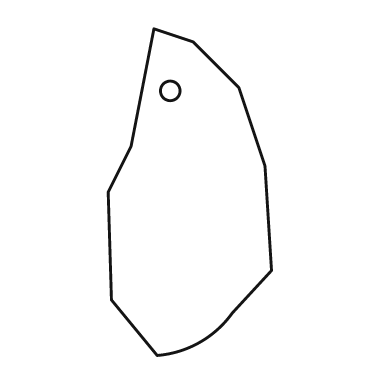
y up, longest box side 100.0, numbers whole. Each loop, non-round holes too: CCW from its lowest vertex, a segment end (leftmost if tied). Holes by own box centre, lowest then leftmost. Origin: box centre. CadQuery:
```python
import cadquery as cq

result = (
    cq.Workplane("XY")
    .moveTo(-10.0, -50.0)
    .threePointArc((3.0, -46.0), (13.0, -37.0))
    .lineTo(25.0, -24.0)
    .lineTo(23.0, 8.0)
    .lineTo(15.0, 32.0)
    .lineTo(1.0, 46.0)
    .lineTo(-11.0, 50.0)
    .lineTo(-18.0, 14.0)
    .lineTo(-25.0, 0.0)
    .lineTo(-24.0, -33.0)
    .close()
    .moveTo(-6.0, 31.0)
    .circle(3.0)
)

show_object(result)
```